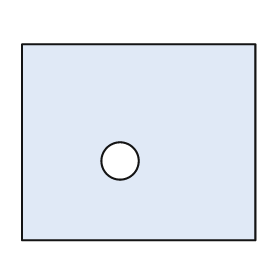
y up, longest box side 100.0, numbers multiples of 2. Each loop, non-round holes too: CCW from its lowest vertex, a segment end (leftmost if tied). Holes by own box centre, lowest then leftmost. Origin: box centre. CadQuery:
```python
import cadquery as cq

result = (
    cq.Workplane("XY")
    .moveTo(-50.0, -42.0)
    .lineTo(50.0, -42.0)
    .lineTo(50.0, 42.0)
    .lineTo(-50.0, 42.0)
    .close()
    .moveTo(-8.0, -8.0)
    .circle(8.0)
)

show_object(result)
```